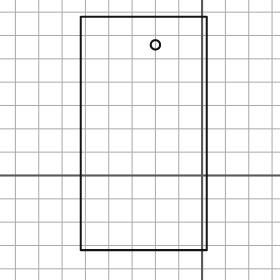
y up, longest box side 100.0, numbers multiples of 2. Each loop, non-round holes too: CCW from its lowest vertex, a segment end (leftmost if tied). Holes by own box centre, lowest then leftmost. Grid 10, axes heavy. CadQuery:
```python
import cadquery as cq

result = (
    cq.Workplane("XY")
    .moveTo(-52.0, -32.0)
    .lineTo(2.0, -32.0)
    .lineTo(2.0, 68.0)
    .lineTo(-52.0, 68.0)
    .close()
    .moveTo(-20.0, 56.0)
    .circle(2.0)
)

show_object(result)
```